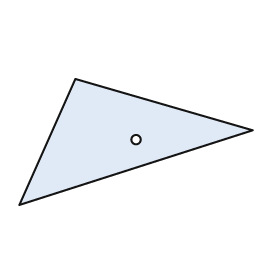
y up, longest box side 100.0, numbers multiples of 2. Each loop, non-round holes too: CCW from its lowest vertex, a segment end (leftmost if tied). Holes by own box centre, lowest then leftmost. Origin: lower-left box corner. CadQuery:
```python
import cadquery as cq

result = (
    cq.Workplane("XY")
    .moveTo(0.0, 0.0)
    .lineTo(100.0, 32.0)
    .lineTo(24.0, 54.0)
    .close()
    .moveTo(50.0, 28.0)
    .circle(2.0)
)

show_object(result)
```